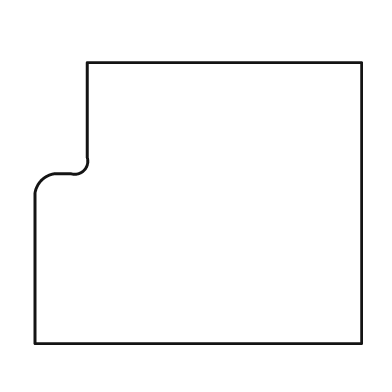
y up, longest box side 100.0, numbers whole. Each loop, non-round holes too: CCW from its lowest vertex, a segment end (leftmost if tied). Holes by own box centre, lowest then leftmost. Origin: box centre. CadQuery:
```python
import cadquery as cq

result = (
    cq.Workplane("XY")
    .moveTo(-50.0, -43.0)
    .lineTo(50.0, -43.0)
    .lineTo(50.0, 43.0)
    .lineTo(-34.0, 43.0)
    .lineTo(-34.0, 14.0)
    .threePointArc((-35.0, 10.0), (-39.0, 9.0))
    .lineTo(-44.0, 9.0)
    .threePointArc((-48.0, 7.0), (-50.0, 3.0))
    .close()
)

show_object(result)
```